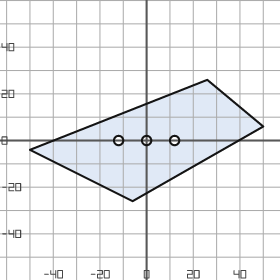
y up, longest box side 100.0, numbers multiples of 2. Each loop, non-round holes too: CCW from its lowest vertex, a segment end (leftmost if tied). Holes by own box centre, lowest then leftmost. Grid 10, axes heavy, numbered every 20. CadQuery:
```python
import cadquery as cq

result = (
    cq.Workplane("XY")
    .moveTo(-6.0, -26.0)
    .lineTo(50.0, 6.0)
    .lineTo(26.0, 26.0)
    .lineTo(-50.0, -4.0)
    .close()
    .moveTo(-12.0, 0.0)
    .circle(2.0)
    .moveTo(0.0, 0.0)
    .circle(2.0)
    .moveTo(12.0, 0.0)
    .circle(2.0)
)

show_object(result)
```